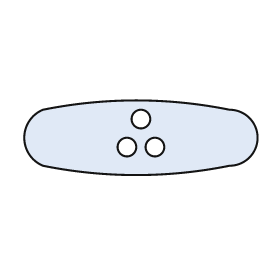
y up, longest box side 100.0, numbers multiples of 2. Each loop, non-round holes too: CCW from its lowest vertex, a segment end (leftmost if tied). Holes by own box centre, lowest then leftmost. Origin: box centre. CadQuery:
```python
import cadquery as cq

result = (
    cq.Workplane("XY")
    .moveTo(-42.0, -12.0)
    .threePointArc((-2.0, -16.0), (38.0, -12.0))
    .threePointArc((50.0, 0.0), (38.0, 12.0))
    .threePointArc((-2.0, 16.0), (-42.0, 12.0))
    .threePointArc((-50.0, 0.0), (-42.0, -12.0))
    .close()
    .moveTo(-6.0, -4.0)
    .circle(4.0)
    .moveTo(6.0, -4.0)
    .circle(4.0)
    .moveTo(0.0, 8.0)
    .circle(4.0)
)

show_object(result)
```